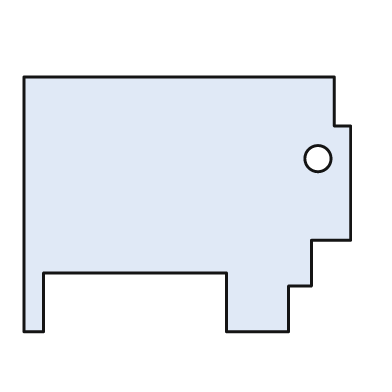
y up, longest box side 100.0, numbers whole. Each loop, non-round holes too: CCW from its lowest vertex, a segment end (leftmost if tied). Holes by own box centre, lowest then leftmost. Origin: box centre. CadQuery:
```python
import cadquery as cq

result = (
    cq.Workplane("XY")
    .moveTo(-50.0, -39.0)
    .lineTo(-44.0, -39.0)
    .lineTo(-44.0, -21.0)
    .lineTo(12.0, -21.0)
    .lineTo(12.0, -39.0)
    .lineTo(31.0, -39.0)
    .lineTo(31.0, -25.0)
    .lineTo(38.0, -25.0)
    .lineTo(38.0, -11.0)
    .lineTo(50.0, -11.0)
    .lineTo(50.0, 24.0)
    .lineTo(45.0, 24.0)
    .lineTo(45.0, 39.0)
    .lineTo(-50.0, 39.0)
    .close()
    .moveTo(40.0, 14.0)
    .circle(4.0)
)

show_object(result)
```